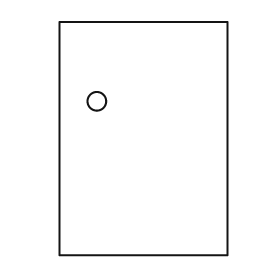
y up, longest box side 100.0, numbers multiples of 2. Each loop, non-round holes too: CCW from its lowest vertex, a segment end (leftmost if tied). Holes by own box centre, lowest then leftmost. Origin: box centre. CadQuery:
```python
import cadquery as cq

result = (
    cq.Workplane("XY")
    .moveTo(-36.0, -50.0)
    .lineTo(36.0, -50.0)
    .lineTo(36.0, 50.0)
    .lineTo(-36.0, 50.0)
    .close()
    .moveTo(-20.0, 16.0)
    .circle(4.0)
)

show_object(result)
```